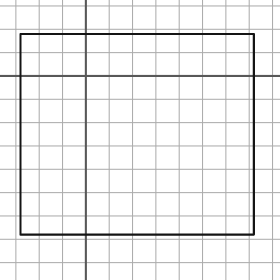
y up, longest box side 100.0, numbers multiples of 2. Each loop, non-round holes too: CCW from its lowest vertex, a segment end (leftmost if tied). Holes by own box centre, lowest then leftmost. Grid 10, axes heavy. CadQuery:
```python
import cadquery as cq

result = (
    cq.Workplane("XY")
    .moveTo(-28.0, -68.0)
    .lineTo(72.0, -68.0)
    .lineTo(72.0, 18.0)
    .lineTo(-28.0, 18.0)
    .close()
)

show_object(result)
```